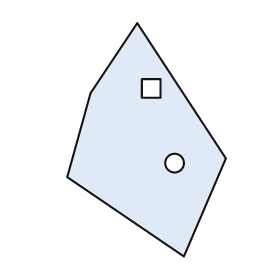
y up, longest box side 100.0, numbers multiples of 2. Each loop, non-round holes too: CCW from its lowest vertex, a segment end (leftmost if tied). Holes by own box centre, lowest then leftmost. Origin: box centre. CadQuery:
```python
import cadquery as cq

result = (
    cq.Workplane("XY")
    .moveTo(16.0, -50.0)
    .lineTo(34.0, -8.0)
    .lineTo(-4.0, 50.0)
    .lineTo(-24.0, 20.0)
    .lineTo(-34.0, -16.0)
    .close()
    .moveTo(12.0, -10.0)
    .circle(4.0)
    .moveTo(-2.0, 18.0)
    .lineTo(6.0, 18.0)
    .lineTo(6.0, 26.0)
    .lineTo(-2.0, 26.0)
    .close()
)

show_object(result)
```